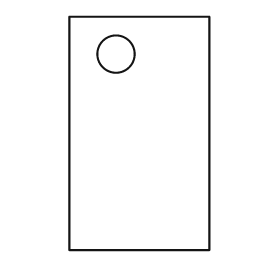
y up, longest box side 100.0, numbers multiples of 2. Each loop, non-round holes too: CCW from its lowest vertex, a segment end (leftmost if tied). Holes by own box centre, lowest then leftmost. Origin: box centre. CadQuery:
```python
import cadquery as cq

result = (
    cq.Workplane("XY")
    .moveTo(-30.0, -50.0)
    .lineTo(30.0, -50.0)
    .lineTo(30.0, 50.0)
    .lineTo(-30.0, 50.0)
    .close()
    .moveTo(-10.0, 34.0)
    .circle(8.0)
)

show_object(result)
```